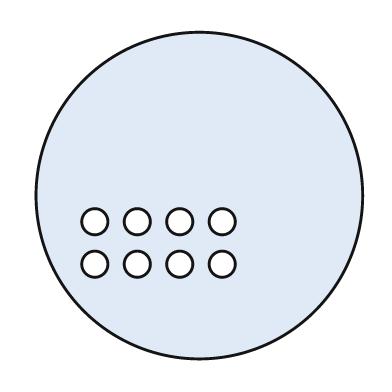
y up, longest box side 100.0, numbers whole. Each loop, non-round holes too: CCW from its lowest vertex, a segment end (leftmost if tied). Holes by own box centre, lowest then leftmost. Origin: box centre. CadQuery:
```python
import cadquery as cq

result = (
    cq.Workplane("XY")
    .moveTo(0.0, 0.0)
    .circle(50.0)
    .moveTo(-32.0, -21.0)
    .circle(4.0)
    .moveTo(-19.0, -21.0)
    .circle(4.0)
    .moveTo(-6.0, -21.0)
    .circle(4.0)
    .moveTo(7.0, -21.0)
    .circle(4.0)
    .moveTo(-32.0, -8.0)
    .circle(4.0)
    .moveTo(-19.0, -8.0)
    .circle(4.0)
    .moveTo(-6.0, -8.0)
    .circle(4.0)
    .moveTo(7.0, -8.0)
    .circle(4.0)
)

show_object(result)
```